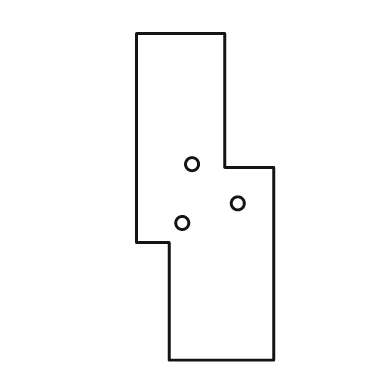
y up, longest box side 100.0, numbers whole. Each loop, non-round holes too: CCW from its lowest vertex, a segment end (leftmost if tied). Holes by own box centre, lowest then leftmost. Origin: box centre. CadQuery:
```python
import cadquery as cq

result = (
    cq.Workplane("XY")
    .moveTo(-11.0, -50.0)
    .lineTo(21.0, -50.0)
    .lineTo(21.0, 9.0)
    .lineTo(6.0, 9.0)
    .lineTo(6.0, 50.0)
    .lineTo(-21.0, 50.0)
    .lineTo(-21.0, -14.0)
    .lineTo(-11.0, -14.0)
    .close()
    .moveTo(-7.0, -8.0)
    .circle(2.0)
    .moveTo(10.0, -2.0)
    .circle(2.0)
    .moveTo(-4.0, 10.0)
    .circle(2.0)
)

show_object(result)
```